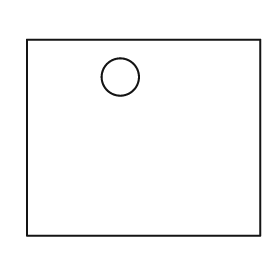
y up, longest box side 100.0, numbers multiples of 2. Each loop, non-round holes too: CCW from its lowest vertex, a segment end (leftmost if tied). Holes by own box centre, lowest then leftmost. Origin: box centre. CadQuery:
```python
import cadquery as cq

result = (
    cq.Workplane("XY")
    .moveTo(-50.0, -42.0)
    .lineTo(50.0, -42.0)
    .lineTo(50.0, 42.0)
    .lineTo(-50.0, 42.0)
    .close()
    .moveTo(-10.0, 26.0)
    .circle(8.0)
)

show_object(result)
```